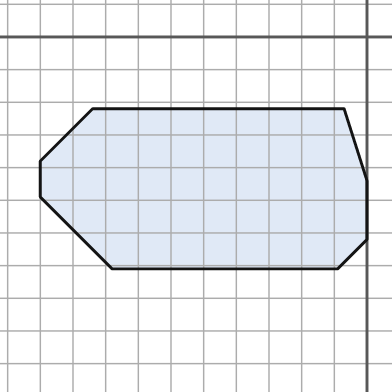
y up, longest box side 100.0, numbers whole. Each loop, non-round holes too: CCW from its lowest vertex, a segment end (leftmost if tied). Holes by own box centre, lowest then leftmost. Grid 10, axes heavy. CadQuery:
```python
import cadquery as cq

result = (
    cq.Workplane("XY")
    .moveTo(-78.0, -71.0)
    .lineTo(-9.0, -71.0)
    .lineTo(0.0, -62.0)
    .lineTo(0.0, -44.0)
    .lineTo(-7.0, -22.0)
    .lineTo(-84.0, -22.0)
    .lineTo(-100.0, -38.0)
    .lineTo(-100.0, -49.0)
    .close()
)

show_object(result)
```